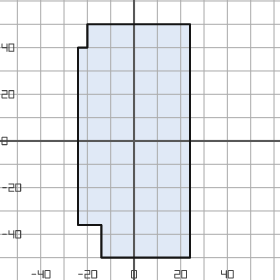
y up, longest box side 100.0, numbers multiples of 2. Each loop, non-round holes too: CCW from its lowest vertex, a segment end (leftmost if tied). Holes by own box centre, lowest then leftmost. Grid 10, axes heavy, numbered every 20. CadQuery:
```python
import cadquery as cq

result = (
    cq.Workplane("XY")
    .moveTo(-14.0, -50.0)
    .lineTo(24.0, -50.0)
    .lineTo(24.0, 50.0)
    .lineTo(-20.0, 50.0)
    .lineTo(-20.0, 40.0)
    .lineTo(-24.0, 40.0)
    .lineTo(-24.0, -36.0)
    .lineTo(-14.0, -36.0)
    .close()
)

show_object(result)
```